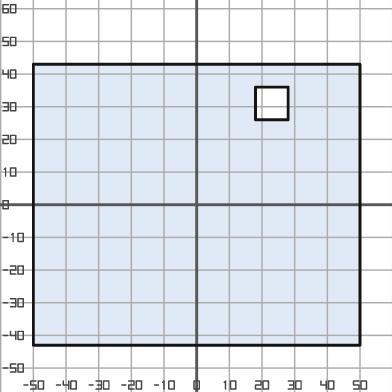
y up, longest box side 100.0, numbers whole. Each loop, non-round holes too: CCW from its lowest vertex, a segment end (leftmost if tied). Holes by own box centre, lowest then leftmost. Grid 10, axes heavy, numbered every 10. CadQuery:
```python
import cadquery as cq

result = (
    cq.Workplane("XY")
    .moveTo(-50.0, -43.0)
    .lineTo(50.0, -43.0)
    .lineTo(50.0, 43.0)
    .lineTo(-50.0, 43.0)
    .close()
    .moveTo(18.0, 26.0)
    .lineTo(28.0, 26.0)
    .lineTo(28.0, 36.0)
    .lineTo(18.0, 36.0)
    .close()
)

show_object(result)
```